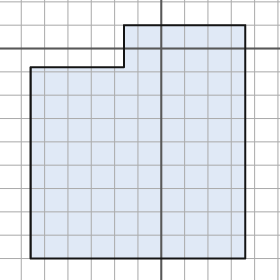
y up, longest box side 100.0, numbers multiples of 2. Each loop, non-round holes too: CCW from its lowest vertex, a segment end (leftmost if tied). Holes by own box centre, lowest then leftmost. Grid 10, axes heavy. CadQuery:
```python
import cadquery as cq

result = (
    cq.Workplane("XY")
    .moveTo(-56.0, -90.0)
    .lineTo(36.0, -90.0)
    .lineTo(36.0, 10.0)
    .lineTo(-16.0, 10.0)
    .lineTo(-16.0, -8.0)
    .lineTo(-56.0, -8.0)
    .close()
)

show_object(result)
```